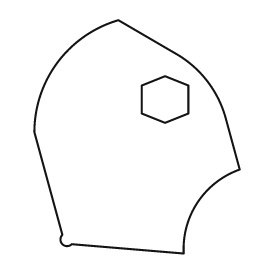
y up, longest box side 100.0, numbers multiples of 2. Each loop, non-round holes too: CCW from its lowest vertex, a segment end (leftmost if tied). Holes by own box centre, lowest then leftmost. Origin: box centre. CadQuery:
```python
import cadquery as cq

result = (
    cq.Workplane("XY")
    .moveTo(20.0, -50.0)
    .threePointArc((26.0, -28.0), (44.0, -14.0))
    .lineTo(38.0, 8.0)
    .threePointArc((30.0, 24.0), (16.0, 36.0))
    .lineTo(-8.0, 50.0)
    .threePointArc((-34.0, 32.0), (-44.0, 2.0))
    .lineTo(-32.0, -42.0)
    .threePointArc((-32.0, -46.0), (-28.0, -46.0))
    .close()
    .moveTo(12.0, 6.0)
    .lineTo(22.0, 10.0)
    .lineTo(22.0, 22.0)
    .lineTo(12.0, 26.0)
    .lineTo(2.0, 22.0)
    .lineTo(2.0, 10.0)
    .close()
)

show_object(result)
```